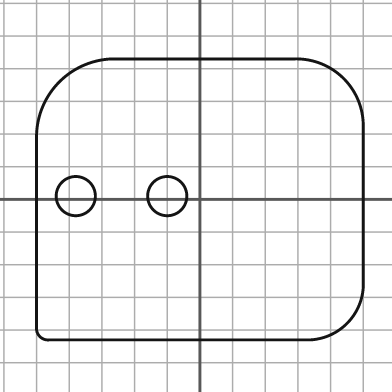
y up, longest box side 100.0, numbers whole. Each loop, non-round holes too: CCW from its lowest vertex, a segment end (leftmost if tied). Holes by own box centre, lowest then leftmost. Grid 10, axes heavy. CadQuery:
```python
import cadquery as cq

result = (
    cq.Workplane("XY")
    .moveTo(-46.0, -43.0)
    .lineTo(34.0, -43.0)
    .threePointArc((45.0, -38.0), (50.0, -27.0))
    .lineTo(50.0, 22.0)
    .threePointArc((44.0, 37.0), (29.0, 43.0))
    .lineTo(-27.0, 43.0)
    .threePointArc((-43.0, 36.0), (-50.0, 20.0))
    .lineTo(-50.0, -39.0)
    .threePointArc((-49.0, -42.0), (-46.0, -43.0))
    .close()
    .moveTo(-38.0, 1.0)
    .circle(6.0)
    .moveTo(-10.0, 1.0)
    .circle(6.0)
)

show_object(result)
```